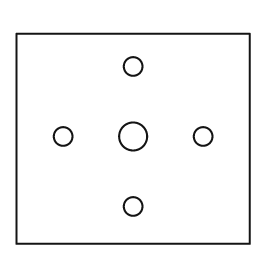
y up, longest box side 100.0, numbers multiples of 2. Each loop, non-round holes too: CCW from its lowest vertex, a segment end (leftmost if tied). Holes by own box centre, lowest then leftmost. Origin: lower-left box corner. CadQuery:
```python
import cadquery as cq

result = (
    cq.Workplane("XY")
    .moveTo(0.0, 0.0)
    .lineTo(100.0, 0.0)
    .lineTo(100.0, 90.0)
    .lineTo(0.0, 90.0)
    .close()
    .moveTo(50.0, 16.0)
    .circle(4.0)
    .moveTo(20.0, 46.0)
    .circle(4.0)
    .moveTo(50.0, 46.0)
    .circle(6.0)
    .moveTo(80.0, 46.0)
    .circle(4.0)
    .moveTo(50.0, 76.0)
    .circle(4.0)
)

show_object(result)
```